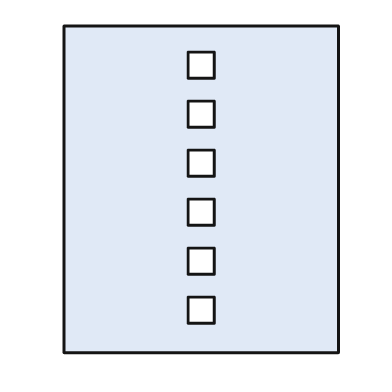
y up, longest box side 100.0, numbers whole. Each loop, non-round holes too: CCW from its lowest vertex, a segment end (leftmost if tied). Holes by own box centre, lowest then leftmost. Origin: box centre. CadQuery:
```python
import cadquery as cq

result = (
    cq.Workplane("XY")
    .moveTo(-42.0, -50.0)
    .lineTo(42.0, -50.0)
    .lineTo(42.0, 50.0)
    .lineTo(-42.0, 50.0)
    .close()
    .moveTo(-4.0, -41.0)
    .lineTo(4.0, -41.0)
    .lineTo(4.0, -33.0)
    .lineTo(-4.0, -33.0)
    .close()
    .moveTo(-4.0, -26.0)
    .lineTo(4.0, -26.0)
    .lineTo(4.0, -18.0)
    .lineTo(-4.0, -18.0)
    .close()
    .moveTo(-4.0, -11.0)
    .lineTo(4.0, -11.0)
    .lineTo(4.0, -3.0)
    .lineTo(-4.0, -3.0)
    .close()
    .moveTo(-4.0, 4.0)
    .lineTo(4.0, 4.0)
    .lineTo(4.0, 12.0)
    .lineTo(-4.0, 12.0)
    .close()
    .moveTo(-4.0, 19.0)
    .lineTo(4.0, 19.0)
    .lineTo(4.0, 27.0)
    .lineTo(-4.0, 27.0)
    .close()
    .moveTo(-4.0, 34.0)
    .lineTo(4.0, 34.0)
    .lineTo(4.0, 42.0)
    .lineTo(-4.0, 42.0)
    .close()
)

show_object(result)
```